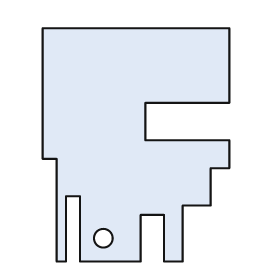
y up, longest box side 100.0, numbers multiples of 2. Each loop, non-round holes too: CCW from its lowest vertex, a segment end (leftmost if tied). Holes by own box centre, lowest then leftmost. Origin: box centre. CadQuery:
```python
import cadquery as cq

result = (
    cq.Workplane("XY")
    .moveTo(-34.0, -50.0)
    .lineTo(-30.0, -50.0)
    .lineTo(-30.0, -22.0)
    .lineTo(-24.0, -22.0)
    .lineTo(-24.0, -50.0)
    .lineTo(2.0, -50.0)
    .lineTo(2.0, -30.0)
    .lineTo(12.0, -30.0)
    .lineTo(12.0, -50.0)
    .lineTo(20.0, -50.0)
    .lineTo(20.0, -26.0)
    .lineTo(32.0, -26.0)
    .lineTo(32.0, -10.0)
    .lineTo(40.0, -10.0)
    .lineTo(40.0, 2.0)
    .lineTo(4.0, 2.0)
    .lineTo(4.0, 18.0)
    .lineTo(40.0, 18.0)
    .lineTo(40.0, 50.0)
    .lineTo(-40.0, 50.0)
    .lineTo(-40.0, -6.0)
    .lineTo(-34.0, -6.0)
    .close()
    .moveTo(-14.0, -40.0)
    .circle(4.0)
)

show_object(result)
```